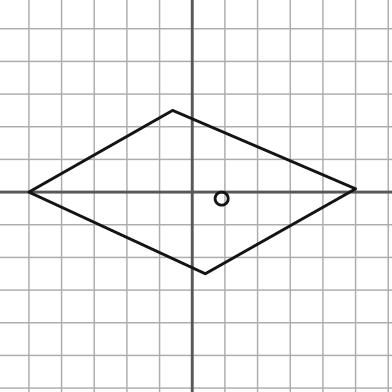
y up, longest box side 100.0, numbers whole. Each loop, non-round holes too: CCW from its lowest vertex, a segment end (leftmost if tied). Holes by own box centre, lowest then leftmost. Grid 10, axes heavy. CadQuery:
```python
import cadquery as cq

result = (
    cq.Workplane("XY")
    .moveTo(4.0, -25.0)
    .lineTo(50.0, 1.0)
    .lineTo(-6.0, 25.0)
    .lineTo(-50.0, 0.0)
    .close()
    .moveTo(9.0, -2.0)
    .circle(2.0)
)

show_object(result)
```